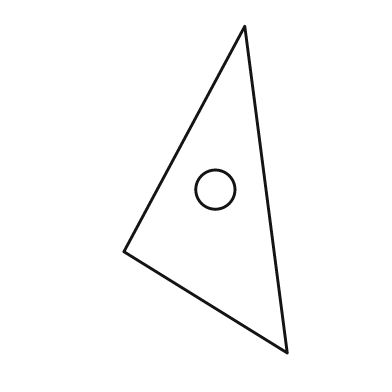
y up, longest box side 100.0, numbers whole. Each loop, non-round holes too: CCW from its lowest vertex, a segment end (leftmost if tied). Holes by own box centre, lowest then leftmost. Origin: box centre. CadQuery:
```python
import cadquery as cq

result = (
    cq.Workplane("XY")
    .moveTo(25.0, -50.0)
    .lineTo(12.0, 50.0)
    .lineTo(-25.0, -19.0)
    .close()
    .moveTo(3.0, 0.0)
    .circle(6.0)
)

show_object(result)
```